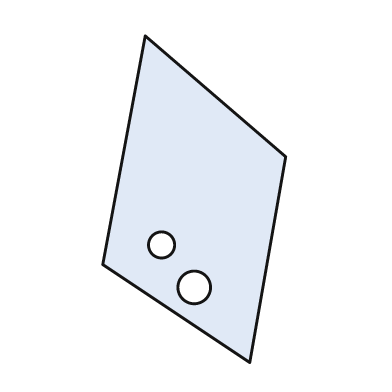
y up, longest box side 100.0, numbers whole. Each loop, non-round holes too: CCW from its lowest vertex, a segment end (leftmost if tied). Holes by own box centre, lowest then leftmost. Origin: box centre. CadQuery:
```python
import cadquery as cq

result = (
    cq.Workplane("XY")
    .moveTo(17.0, -50.0)
    .lineTo(28.0, 13.0)
    .lineTo(-15.0, 50.0)
    .lineTo(-28.0, -20.0)
    .close()
    .moveTo(0.0, -27.0)
    .circle(5.0)
    .moveTo(-10.0, -14.0)
    .circle(4.0)
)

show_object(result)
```